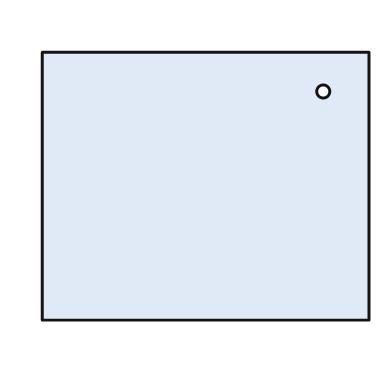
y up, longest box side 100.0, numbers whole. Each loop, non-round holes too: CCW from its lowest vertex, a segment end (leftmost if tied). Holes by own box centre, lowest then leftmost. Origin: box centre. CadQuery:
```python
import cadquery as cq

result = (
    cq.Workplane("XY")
    .moveTo(-50.0, -41.0)
    .lineTo(50.0, -41.0)
    .lineTo(50.0, 41.0)
    .lineTo(-50.0, 41.0)
    .close()
    .moveTo(36.0, 29.0)
    .circle(2.0)
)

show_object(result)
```